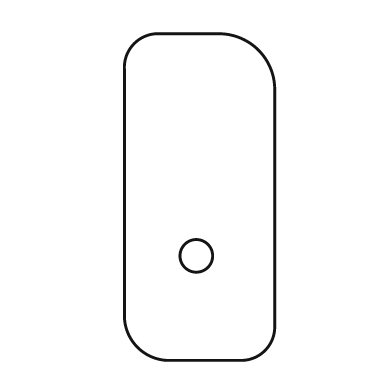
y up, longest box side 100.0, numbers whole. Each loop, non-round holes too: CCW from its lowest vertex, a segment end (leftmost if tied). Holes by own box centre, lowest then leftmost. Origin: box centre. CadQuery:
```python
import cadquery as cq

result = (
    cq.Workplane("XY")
    .moveTo(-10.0, -50.0)
    .lineTo(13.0, -50.0)
    .threePointArc((20.0, -47.0), (23.0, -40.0))
    .lineTo(23.0, 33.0)
    .threePointArc((18.0, 45.0), (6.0, 50.0))
    .lineTo(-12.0, 50.0)
    .threePointArc((-20.0, 47.0), (-23.0, 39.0))
    .lineTo(-23.0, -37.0)
    .threePointArc((-19.0, -46.0), (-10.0, -50.0))
    .close()
    .moveTo(-1.0, -18.0)
    .circle(5.0)
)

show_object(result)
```